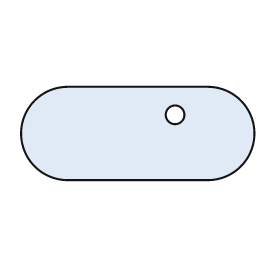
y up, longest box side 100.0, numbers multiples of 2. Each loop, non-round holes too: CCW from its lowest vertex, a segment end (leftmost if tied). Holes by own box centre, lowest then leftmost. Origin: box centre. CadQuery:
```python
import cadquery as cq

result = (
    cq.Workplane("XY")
    .moveTo(-30.0, -20.0)
    .lineTo(30.0, -20.0)
    .threePointArc((50.0, 0.0), (30.0, 20.0))
    .lineTo(-30.0, 20.0)
    .threePointArc((-50.0, 0.0), (-30.0, -20.0))
    .close()
    .moveTo(16.0, 8.0)
    .circle(4.0)
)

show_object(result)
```